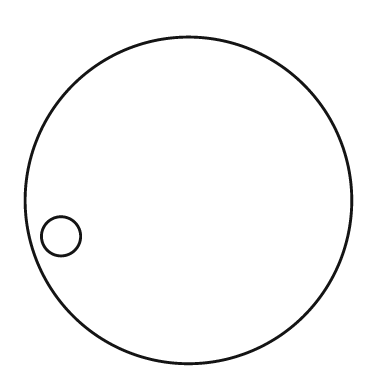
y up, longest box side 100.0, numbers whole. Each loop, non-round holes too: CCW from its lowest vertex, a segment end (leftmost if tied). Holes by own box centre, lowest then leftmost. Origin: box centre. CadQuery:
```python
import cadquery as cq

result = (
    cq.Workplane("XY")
    .moveTo(0.0, 0.0)
    .circle(50.0)
    .moveTo(-39.0, -11.0)
    .circle(6.0)
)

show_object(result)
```